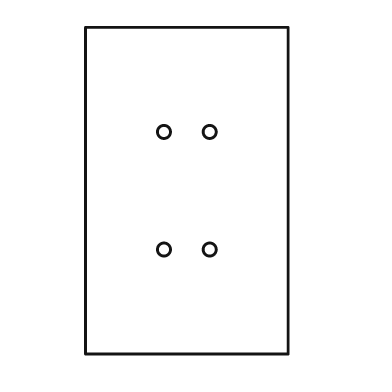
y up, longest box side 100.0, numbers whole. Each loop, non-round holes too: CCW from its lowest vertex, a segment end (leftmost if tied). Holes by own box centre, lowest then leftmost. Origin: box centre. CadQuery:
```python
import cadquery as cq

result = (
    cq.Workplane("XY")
    .moveTo(-31.0, -50.0)
    .lineTo(31.0, -50.0)
    .lineTo(31.0, 50.0)
    .lineTo(-31.0, 50.0)
    .close()
    .moveTo(-7.0, -18.0)
    .circle(2.0)
    .moveTo(7.0, -18.0)
    .circle(2.0)
    .moveTo(-7.0, 18.0)
    .circle(2.0)
    .moveTo(7.0, 18.0)
    .circle(2.0)
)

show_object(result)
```